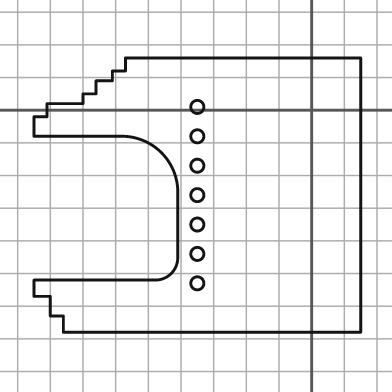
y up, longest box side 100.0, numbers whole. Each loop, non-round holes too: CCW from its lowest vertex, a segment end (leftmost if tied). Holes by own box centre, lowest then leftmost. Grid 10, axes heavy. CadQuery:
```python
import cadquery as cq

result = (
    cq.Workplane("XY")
    .moveTo(-76.0, -68.0)
    .lineTo(15.0, -68.0)
    .lineTo(15.0, 16.0)
    .lineTo(-57.0, 16.0)
    .lineTo(-57.0, 12.0)
    .lineTo(-61.0, 12.0)
    .lineTo(-61.0, 9.0)
    .lineTo(-66.0, 9.0)
    .lineTo(-66.0, 5.0)
    .lineTo(-70.0, 5.0)
    .lineTo(-70.0, 2.0)
    .lineTo(-81.0, 2.0)
    .lineTo(-81.0, -2.0)
    .lineTo(-85.0, -2.0)
    .lineTo(-85.0, -8.0)
    .lineTo(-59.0, -8.0)
    .threePointArc((-46.0, -13.0), (-41.0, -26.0))
    .lineTo(-41.0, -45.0)
    .threePointArc((-43.0, -50.0), (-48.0, -52.0))
    .lineTo(-85.0, -52.0)
    .lineTo(-85.0, -57.0)
    .lineTo(-80.0, -57.0)
    .lineTo(-80.0, -63.0)
    .lineTo(-76.0, -63.0)
    .close()
    .moveTo(-35.0, -53.0)
    .circle(2.0)
    .moveTo(-35.0, -44.0)
    .circle(2.0)
    .moveTo(-35.0, -35.0)
    .circle(2.0)
    .moveTo(-35.0, -26.0)
    .circle(2.0)
    .moveTo(-35.0, -17.0)
    .circle(2.0)
    .moveTo(-35.0, -8.0)
    .circle(2.0)
    .moveTo(-35.0, 1.0)
    .circle(2.0)
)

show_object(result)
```